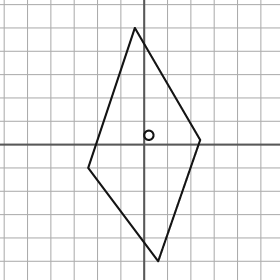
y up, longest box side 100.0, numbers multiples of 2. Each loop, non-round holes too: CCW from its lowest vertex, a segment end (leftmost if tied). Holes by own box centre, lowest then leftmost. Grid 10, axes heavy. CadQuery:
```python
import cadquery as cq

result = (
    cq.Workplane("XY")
    .moveTo(6.0, -50.0)
    .lineTo(24.0, 2.0)
    .lineTo(-4.0, 50.0)
    .lineTo(-24.0, -10.0)
    .close()
    .moveTo(2.0, 4.0)
    .circle(2.0)
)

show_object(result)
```